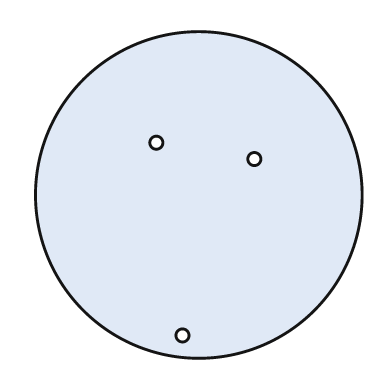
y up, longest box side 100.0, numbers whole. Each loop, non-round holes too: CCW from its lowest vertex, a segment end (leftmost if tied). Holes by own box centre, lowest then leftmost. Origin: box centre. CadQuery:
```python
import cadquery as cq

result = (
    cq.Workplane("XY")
    .moveTo(0.0, 0.0)
    .circle(50.0)
    .moveTo(-5.0, -43.0)
    .circle(2.0)
    .moveTo(17.0, 11.0)
    .circle(2.0)
    .moveTo(-13.0, 16.0)
    .circle(2.0)
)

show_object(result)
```